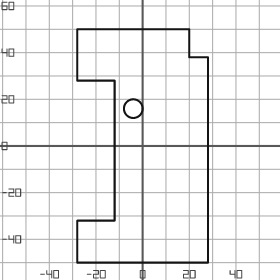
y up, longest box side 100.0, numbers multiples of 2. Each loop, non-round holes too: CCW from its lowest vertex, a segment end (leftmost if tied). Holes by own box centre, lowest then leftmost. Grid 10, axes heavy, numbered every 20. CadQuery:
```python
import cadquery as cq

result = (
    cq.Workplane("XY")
    .moveTo(-28.0, -50.0)
    .lineTo(28.0, -50.0)
    .lineTo(28.0, 38.0)
    .lineTo(20.0, 38.0)
    .lineTo(20.0, 50.0)
    .lineTo(-28.0, 50.0)
    .lineTo(-28.0, 28.0)
    .lineTo(-12.0, 28.0)
    .lineTo(-12.0, -32.0)
    .lineTo(-28.0, -32.0)
    .close()
    .moveTo(-4.0, 16.0)
    .circle(4.0)
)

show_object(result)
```